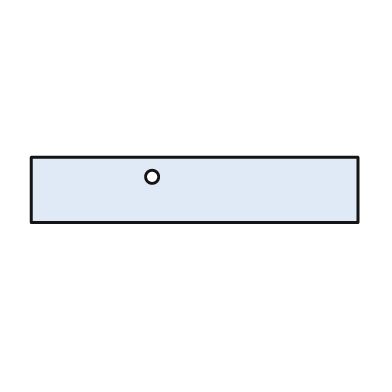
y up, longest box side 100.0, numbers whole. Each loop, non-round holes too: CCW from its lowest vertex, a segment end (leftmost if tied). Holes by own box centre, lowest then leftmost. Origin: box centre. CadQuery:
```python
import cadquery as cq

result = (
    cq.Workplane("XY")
    .moveTo(-50.0, -10.0)
    .lineTo(50.0, -10.0)
    .lineTo(50.0, 10.0)
    .lineTo(-50.0, 10.0)
    .close()
    .moveTo(-13.0, 4.0)
    .circle(2.0)
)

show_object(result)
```